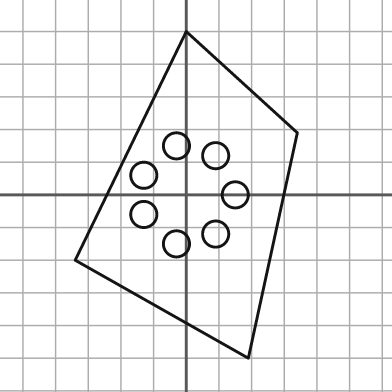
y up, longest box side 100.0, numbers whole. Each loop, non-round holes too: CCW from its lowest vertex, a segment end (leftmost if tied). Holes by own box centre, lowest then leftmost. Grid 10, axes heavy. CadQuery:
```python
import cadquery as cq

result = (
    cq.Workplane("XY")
    .moveTo(19.0, -50.0)
    .lineTo(34.0, 19.0)
    .lineTo(0.0, 50.0)
    .lineTo(-34.0, -20.0)
    .close()
    .moveTo(-3.0, -15.0)
    .circle(4.0)
    .moveTo(9.0, -12.0)
    .circle(4.0)
    .moveTo(-13.0, -6.0)
    .circle(4.0)
    .moveTo(15.0, 0.0)
    .circle(4.0)
    .moveTo(-13.0, 6.0)
    .circle(4.0)
    .moveTo(9.0, 12.0)
    .circle(4.0)
    .moveTo(-3.0, 15.0)
    .circle(4.0)
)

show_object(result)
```